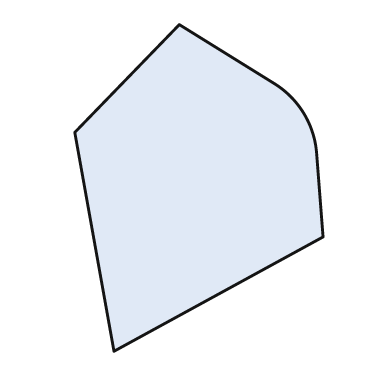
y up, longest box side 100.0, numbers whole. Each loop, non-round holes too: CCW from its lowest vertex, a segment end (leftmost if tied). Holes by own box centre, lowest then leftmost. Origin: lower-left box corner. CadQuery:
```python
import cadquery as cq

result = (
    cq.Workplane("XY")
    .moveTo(12.0, 0.0)
    .lineTo(76.0, 35.0)
    .lineTo(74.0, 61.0)
    .threePointArc((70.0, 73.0), (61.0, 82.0))
    .lineTo(32.0, 100.0)
    .lineTo(0.0, 67.0)
    .close()
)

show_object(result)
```